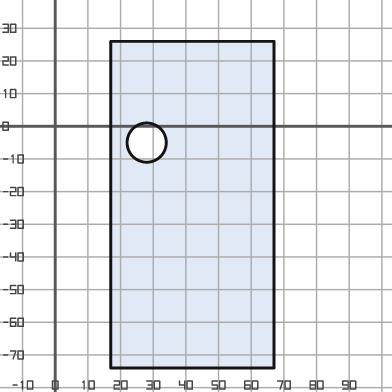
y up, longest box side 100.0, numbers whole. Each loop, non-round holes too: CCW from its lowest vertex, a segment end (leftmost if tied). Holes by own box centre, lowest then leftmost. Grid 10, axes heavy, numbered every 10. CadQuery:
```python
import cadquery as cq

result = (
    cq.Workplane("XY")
    .moveTo(17.0, -74.0)
    .lineTo(67.0, -74.0)
    .lineTo(67.0, 26.0)
    .lineTo(17.0, 26.0)
    .close()
    .moveTo(28.0, -5.0)
    .circle(6.0)
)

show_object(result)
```